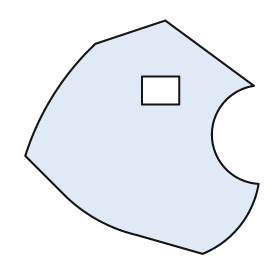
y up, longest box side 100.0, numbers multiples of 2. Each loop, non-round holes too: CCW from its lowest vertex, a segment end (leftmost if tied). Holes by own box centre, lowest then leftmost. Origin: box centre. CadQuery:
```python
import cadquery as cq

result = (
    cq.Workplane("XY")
    .moveTo(26.0, -50.0)
    .threePointArc((42.0, -38.0), (50.0, -20.0))
    .threePointArc((30.0, 0.0), (48.0, 22.0))
    .lineTo(10.0, 50.0)
    .lineTo(-20.0, 40.0)
    .threePointArc((-38.0, 18.0), (-50.0, -8.0))
    .lineTo(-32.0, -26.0)
    .threePointArc((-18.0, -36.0), (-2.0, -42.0))
    .close()
    .moveTo(0.0, 14.0)
    .lineTo(16.0, 14.0)
    .lineTo(16.0, 26.0)
    .lineTo(0.0, 26.0)
    .close()
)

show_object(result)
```